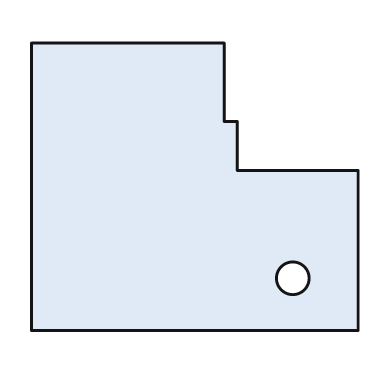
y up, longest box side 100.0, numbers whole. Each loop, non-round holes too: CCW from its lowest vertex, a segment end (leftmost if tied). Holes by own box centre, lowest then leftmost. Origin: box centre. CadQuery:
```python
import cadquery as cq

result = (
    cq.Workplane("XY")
    .moveTo(-50.0, -44.0)
    .lineTo(50.0, -44.0)
    .lineTo(50.0, 5.0)
    .lineTo(13.0, 5.0)
    .lineTo(13.0, 20.0)
    .lineTo(9.0, 20.0)
    .lineTo(9.0, 44.0)
    .lineTo(-50.0, 44.0)
    .close()
    .moveTo(30.0, -28.0)
    .circle(5.0)
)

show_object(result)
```